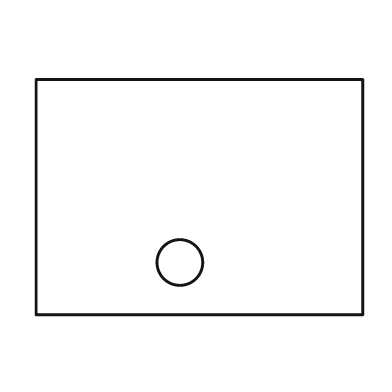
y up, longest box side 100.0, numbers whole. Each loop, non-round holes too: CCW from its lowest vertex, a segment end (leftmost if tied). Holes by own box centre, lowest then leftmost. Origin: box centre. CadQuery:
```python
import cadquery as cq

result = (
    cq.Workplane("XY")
    .moveTo(-50.0, -36.0)
    .lineTo(50.0, -36.0)
    .lineTo(50.0, 36.0)
    .lineTo(-50.0, 36.0)
    .close()
    .moveTo(-6.0, -20.0)
    .circle(7.0)
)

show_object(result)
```